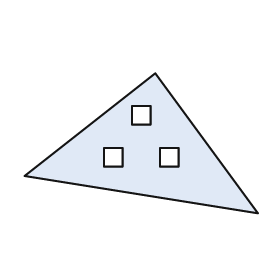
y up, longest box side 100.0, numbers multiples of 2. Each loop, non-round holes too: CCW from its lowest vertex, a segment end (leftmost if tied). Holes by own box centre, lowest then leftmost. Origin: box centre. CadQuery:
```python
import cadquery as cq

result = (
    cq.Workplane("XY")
    .moveTo(50.0, -30.0)
    .lineTo(6.0, 30.0)
    .lineTo(-50.0, -14.0)
    .close()
    .moveTo(-16.0, -10.0)
    .lineTo(-8.0, -10.0)
    .lineTo(-8.0, -2.0)
    .lineTo(-16.0, -2.0)
    .close()
    .moveTo(8.0, -10.0)
    .lineTo(16.0, -10.0)
    .lineTo(16.0, -2.0)
    .lineTo(8.0, -2.0)
    .close()
    .moveTo(-4.0, 8.0)
    .lineTo(4.0, 8.0)
    .lineTo(4.0, 16.0)
    .lineTo(-4.0, 16.0)
    .close()
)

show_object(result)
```